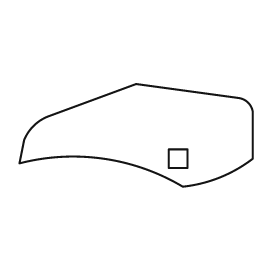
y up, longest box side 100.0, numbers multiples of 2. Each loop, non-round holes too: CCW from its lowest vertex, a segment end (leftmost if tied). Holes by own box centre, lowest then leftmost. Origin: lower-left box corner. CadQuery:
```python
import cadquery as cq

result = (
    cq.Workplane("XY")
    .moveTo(70.0, 0.0)
    .threePointArc((86.0, 4.0), (100.0, 12.0))
    .lineTo(100.0, 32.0)
    .threePointArc((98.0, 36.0), (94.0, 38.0))
    .lineTo(50.0, 44.0)
    .lineTo(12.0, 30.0)
    .threePointArc((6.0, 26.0), (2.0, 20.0))
    .lineTo(0.0, 10.0)
    .threePointArc((36.0, 12.0), (70.0, 0.0))
    .close()
    .moveTo(64.0, 8.0)
    .lineTo(72.0, 8.0)
    .lineTo(72.0, 16.0)
    .lineTo(64.0, 16.0)
    .close()
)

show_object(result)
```